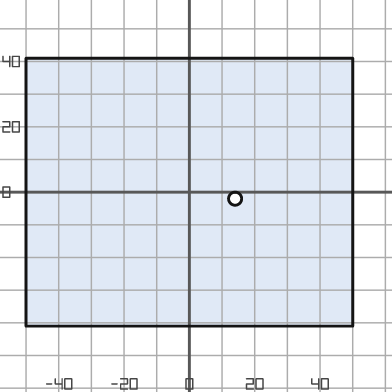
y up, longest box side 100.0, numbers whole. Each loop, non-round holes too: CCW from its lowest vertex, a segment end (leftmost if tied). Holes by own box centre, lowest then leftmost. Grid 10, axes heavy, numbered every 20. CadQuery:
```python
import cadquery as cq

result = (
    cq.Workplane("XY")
    .moveTo(-50.0, -41.0)
    .lineTo(50.0, -41.0)
    .lineTo(50.0, 41.0)
    .lineTo(-50.0, 41.0)
    .close()
    .moveTo(14.0, -2.0)
    .circle(2.0)
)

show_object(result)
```